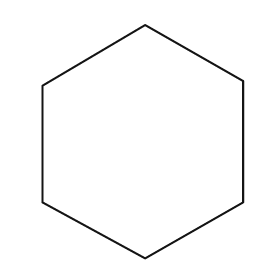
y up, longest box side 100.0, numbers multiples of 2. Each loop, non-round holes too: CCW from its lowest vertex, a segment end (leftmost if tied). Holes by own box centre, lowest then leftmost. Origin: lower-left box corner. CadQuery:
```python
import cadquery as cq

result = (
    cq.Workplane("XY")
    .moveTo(44.0, 0.0)
    .lineTo(86.0, 24.0)
    .lineTo(86.0, 76.0)
    .lineTo(44.0, 100.0)
    .lineTo(0.0, 74.0)
    .lineTo(0.0, 24.0)
    .close()
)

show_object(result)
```